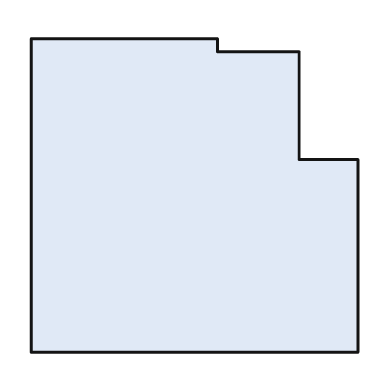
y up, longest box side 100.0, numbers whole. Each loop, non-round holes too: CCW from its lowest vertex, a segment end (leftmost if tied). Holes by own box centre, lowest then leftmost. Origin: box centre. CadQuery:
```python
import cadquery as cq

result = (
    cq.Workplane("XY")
    .moveTo(-50.0, -48.0)
    .lineTo(50.0, -48.0)
    .lineTo(50.0, 11.0)
    .lineTo(32.0, 11.0)
    .lineTo(32.0, 44.0)
    .lineTo(7.0, 44.0)
    .lineTo(7.0, 48.0)
    .lineTo(-50.0, 48.0)
    .close()
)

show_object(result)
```